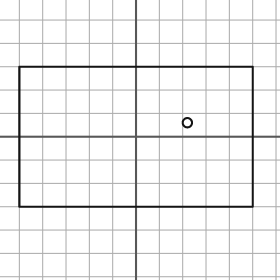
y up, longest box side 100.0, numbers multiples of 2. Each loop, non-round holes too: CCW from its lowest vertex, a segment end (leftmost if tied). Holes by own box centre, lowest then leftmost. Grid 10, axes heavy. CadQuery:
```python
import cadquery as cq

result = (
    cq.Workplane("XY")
    .moveTo(-50.0, -30.0)
    .lineTo(50.0, -30.0)
    .lineTo(50.0, 30.0)
    .lineTo(-50.0, 30.0)
    .close()
    .moveTo(22.0, 6.0)
    .circle(2.0)
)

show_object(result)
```